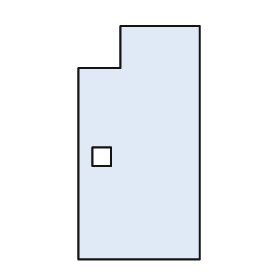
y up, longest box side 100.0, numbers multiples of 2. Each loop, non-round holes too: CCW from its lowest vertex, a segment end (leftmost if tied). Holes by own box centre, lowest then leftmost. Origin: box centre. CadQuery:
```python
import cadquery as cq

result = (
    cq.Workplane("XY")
    .moveTo(-26.0, -50.0)
    .lineTo(26.0, -50.0)
    .lineTo(26.0, 50.0)
    .lineTo(-8.0, 50.0)
    .lineTo(-8.0, 32.0)
    .lineTo(-26.0, 32.0)
    .close()
    .moveTo(-20.0, -10.0)
    .lineTo(-12.0, -10.0)
    .lineTo(-12.0, -2.0)
    .lineTo(-20.0, -2.0)
    .close()
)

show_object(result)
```